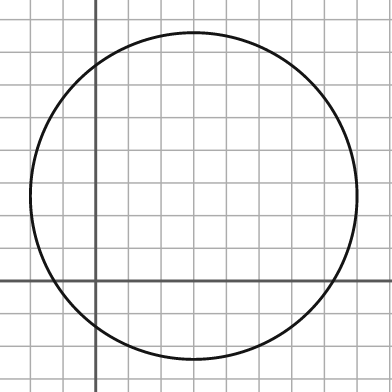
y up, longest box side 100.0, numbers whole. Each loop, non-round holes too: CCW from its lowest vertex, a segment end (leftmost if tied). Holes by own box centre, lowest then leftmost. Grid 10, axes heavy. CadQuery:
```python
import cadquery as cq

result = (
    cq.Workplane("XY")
    .moveTo(30.0, 26.0)
    .circle(50.0)
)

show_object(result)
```